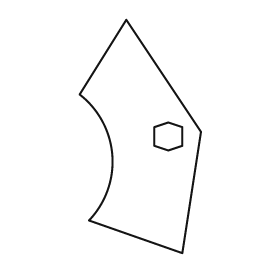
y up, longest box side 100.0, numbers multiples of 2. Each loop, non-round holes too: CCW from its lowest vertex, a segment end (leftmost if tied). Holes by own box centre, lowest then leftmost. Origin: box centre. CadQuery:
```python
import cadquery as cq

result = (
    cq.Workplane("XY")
    .moveTo(18.0, -50.0)
    .lineTo(26.0, 2.0)
    .lineTo(-6.0, 50.0)
    .lineTo(-26.0, 18.0)
    .threePointArc((-12.0, -8.0), (-22.0, -36.0))
    .close()
    .moveTo(12.0, -6.0)
    .lineTo(18.0, -4.0)
    .lineTo(18.0, 4.0)
    .lineTo(12.0, 6.0)
    .lineTo(6.0, 4.0)
    .lineTo(6.0, -4.0)
    .close()
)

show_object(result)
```